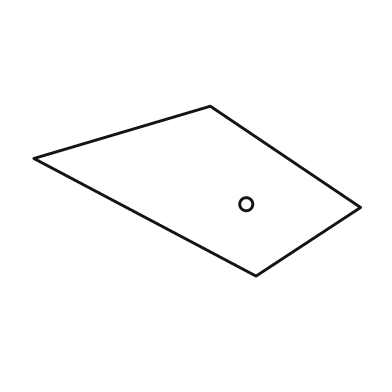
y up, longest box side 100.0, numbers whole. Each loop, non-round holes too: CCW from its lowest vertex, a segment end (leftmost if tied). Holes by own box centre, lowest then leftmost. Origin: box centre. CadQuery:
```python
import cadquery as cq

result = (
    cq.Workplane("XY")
    .moveTo(18.0, -26.0)
    .lineTo(50.0, -5.0)
    .lineTo(4.0, 26.0)
    .lineTo(-50.0, 10.0)
    .close()
    .moveTo(15.0, -4.0)
    .circle(2.0)
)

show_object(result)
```